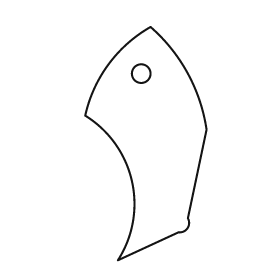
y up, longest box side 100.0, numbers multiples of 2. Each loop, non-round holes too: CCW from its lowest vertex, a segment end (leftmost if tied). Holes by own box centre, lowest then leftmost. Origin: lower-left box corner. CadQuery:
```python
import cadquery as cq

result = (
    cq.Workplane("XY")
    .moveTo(14.0, 0.0)
    .lineTo(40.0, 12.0)
    .threePointArc((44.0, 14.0), (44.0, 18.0))
    .lineTo(52.0, 56.0)
    .threePointArc((44.0, 80.0), (28.0, 100.0))
    .threePointArc((10.0, 84.0), (0.0, 62.0))
    .threePointArc((20.0, 34.0), (14.0, 0.0))
    .close()
    .moveTo(24.0, 80.0)
    .circle(4.0)
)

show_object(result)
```